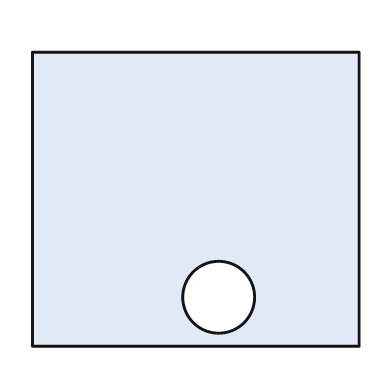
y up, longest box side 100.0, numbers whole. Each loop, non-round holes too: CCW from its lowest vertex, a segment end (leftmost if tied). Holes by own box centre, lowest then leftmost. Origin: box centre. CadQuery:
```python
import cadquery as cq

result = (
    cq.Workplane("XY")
    .moveTo(-50.0, -45.0)
    .lineTo(50.0, -45.0)
    .lineTo(50.0, 45.0)
    .lineTo(-50.0, 45.0)
    .close()
    .moveTo(7.0, -30.0)
    .circle(11.0)
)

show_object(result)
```